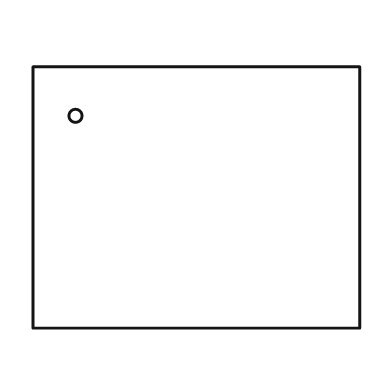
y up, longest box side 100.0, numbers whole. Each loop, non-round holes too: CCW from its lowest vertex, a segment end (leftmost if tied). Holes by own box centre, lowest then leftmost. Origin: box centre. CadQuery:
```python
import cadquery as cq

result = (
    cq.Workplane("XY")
    .moveTo(-50.0, -40.0)
    .lineTo(50.0, -40.0)
    .lineTo(50.0, 40.0)
    .lineTo(-50.0, 40.0)
    .close()
    .moveTo(-37.0, 25.0)
    .circle(2.0)
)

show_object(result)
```